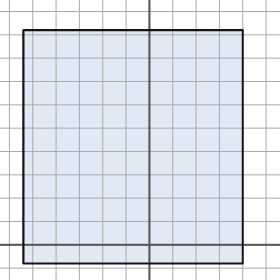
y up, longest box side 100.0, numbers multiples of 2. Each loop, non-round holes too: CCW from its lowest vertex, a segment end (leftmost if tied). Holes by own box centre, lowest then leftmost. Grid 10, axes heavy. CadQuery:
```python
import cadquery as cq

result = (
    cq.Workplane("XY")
    .moveTo(-54.0, -8.0)
    .lineTo(40.0, -8.0)
    .lineTo(40.0, 92.0)
    .lineTo(-54.0, 92.0)
    .close()
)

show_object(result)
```